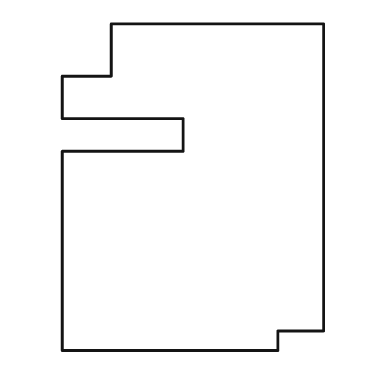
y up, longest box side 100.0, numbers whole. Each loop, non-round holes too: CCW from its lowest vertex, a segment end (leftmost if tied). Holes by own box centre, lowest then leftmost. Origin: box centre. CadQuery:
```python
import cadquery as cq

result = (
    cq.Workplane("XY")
    .moveTo(-40.0, -50.0)
    .lineTo(26.0, -50.0)
    .lineTo(26.0, -44.0)
    .lineTo(40.0, -44.0)
    .lineTo(40.0, 50.0)
    .lineTo(-25.0, 50.0)
    .lineTo(-25.0, 34.0)
    .lineTo(-40.0, 34.0)
    .lineTo(-40.0, 21.0)
    .lineTo(-3.0, 21.0)
    .lineTo(-3.0, 11.0)
    .lineTo(-40.0, 11.0)
    .close()
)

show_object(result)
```